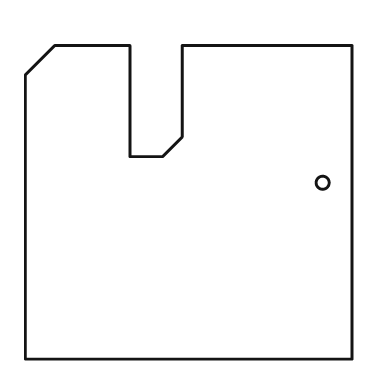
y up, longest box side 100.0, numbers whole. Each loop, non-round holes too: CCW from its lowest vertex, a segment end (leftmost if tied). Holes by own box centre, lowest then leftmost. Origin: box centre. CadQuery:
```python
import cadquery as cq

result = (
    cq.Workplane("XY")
    .moveTo(-50.0, -48.0)
    .lineTo(50.0, -48.0)
    .lineTo(50.0, 48.0)
    .lineTo(-2.0, 48.0)
    .lineTo(-2.0, 20.0)
    .lineTo(-8.0, 14.0)
    .lineTo(-18.0, 14.0)
    .lineTo(-18.0, 48.0)
    .lineTo(-41.0, 48.0)
    .lineTo(-50.0, 39.0)
    .close()
    .moveTo(41.0, 6.0)
    .circle(2.0)
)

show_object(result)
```